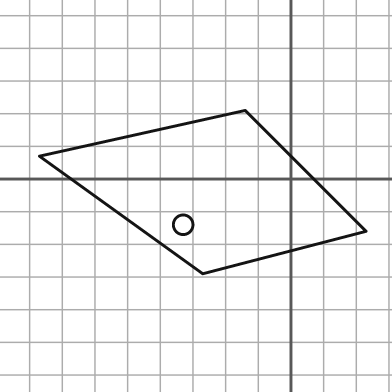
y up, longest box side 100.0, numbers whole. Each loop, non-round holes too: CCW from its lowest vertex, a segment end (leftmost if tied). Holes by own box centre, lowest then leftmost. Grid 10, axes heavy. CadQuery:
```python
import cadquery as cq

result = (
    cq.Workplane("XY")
    .moveTo(-27.0, -29.0)
    .lineTo(23.0, -16.0)
    .lineTo(-14.0, 21.0)
    .lineTo(-77.0, 7.0)
    .close()
    .moveTo(-33.0, -14.0)
    .circle(3.0)
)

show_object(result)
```